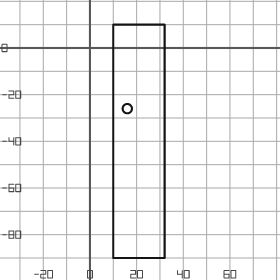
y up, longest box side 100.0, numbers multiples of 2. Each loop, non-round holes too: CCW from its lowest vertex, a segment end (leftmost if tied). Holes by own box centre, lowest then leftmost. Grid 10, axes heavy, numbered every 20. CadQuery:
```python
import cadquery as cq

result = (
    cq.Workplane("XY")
    .moveTo(10.0, -90.0)
    .lineTo(32.0, -90.0)
    .lineTo(32.0, 10.0)
    .lineTo(10.0, 10.0)
    .close()
    .moveTo(16.0, -26.0)
    .circle(2.0)
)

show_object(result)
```